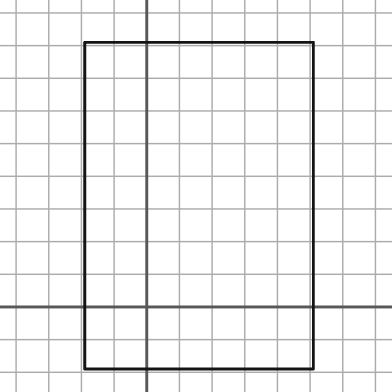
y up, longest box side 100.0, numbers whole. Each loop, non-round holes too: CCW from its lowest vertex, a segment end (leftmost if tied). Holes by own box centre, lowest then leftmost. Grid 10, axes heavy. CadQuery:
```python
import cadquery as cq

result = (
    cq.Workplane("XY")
    .moveTo(-19.0, -19.0)
    .lineTo(51.0, -19.0)
    .lineTo(51.0, 81.0)
    .lineTo(-19.0, 81.0)
    .close()
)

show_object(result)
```